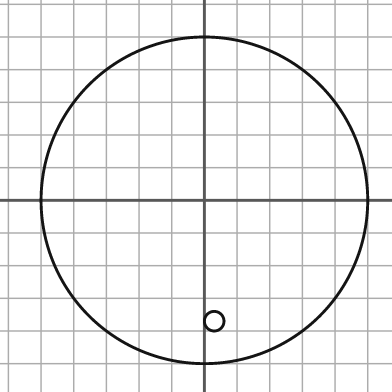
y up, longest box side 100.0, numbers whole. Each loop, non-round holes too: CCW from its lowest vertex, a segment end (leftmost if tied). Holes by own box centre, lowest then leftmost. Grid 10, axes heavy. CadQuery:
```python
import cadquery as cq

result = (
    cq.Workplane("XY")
    .moveTo(0.0, 0.0)
    .circle(50.0)
    .moveTo(3.0, -37.0)
    .circle(3.0)
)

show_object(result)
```